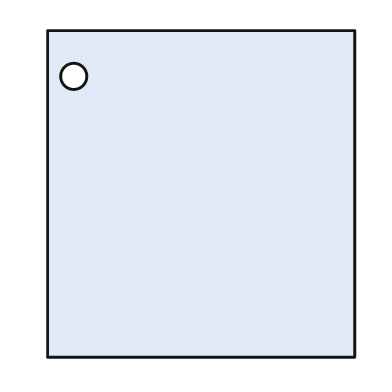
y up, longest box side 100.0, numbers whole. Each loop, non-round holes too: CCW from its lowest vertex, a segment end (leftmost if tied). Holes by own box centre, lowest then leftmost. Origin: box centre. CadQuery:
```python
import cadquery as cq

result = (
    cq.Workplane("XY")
    .moveTo(-47.0, -50.0)
    .lineTo(47.0, -50.0)
    .lineTo(47.0, 50.0)
    .lineTo(-47.0, 50.0)
    .close()
    .moveTo(-39.0, 36.0)
    .circle(4.0)
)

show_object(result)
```